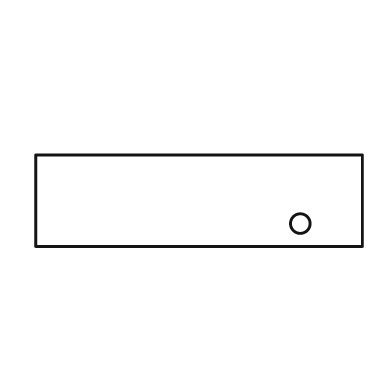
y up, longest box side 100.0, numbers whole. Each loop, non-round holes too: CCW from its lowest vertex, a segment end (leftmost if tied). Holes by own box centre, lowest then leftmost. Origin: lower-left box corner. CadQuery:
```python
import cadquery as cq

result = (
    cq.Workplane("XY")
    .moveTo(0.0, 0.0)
    .lineTo(100.0, 0.0)
    .lineTo(100.0, 28.0)
    .lineTo(0.0, 28.0)
    .close()
    .moveTo(81.0, 7.0)
    .circle(3.0)
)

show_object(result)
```